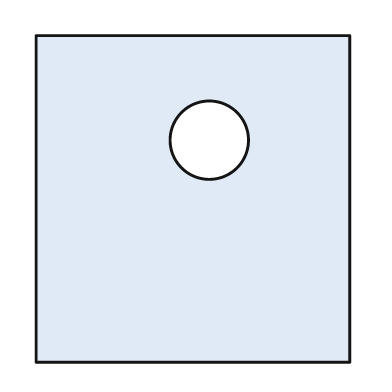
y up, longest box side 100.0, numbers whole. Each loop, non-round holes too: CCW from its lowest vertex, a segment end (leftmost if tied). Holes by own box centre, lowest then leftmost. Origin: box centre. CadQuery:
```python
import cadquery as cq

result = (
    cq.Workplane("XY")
    .moveTo(-48.0, -50.0)
    .lineTo(48.0, -50.0)
    .lineTo(48.0, 50.0)
    .lineTo(-48.0, 50.0)
    .close()
    .moveTo(5.0, 18.0)
    .circle(12.0)
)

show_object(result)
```